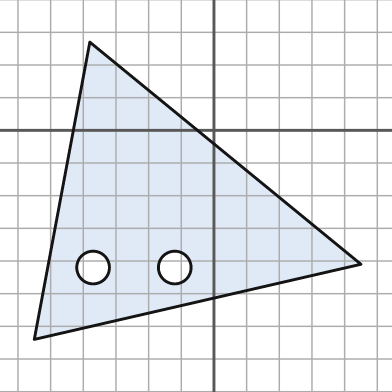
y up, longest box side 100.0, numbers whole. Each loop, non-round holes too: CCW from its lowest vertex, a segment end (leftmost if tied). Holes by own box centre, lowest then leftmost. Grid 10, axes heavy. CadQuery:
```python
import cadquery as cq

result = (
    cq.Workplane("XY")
    .moveTo(-55.0, -64.0)
    .lineTo(45.0, -41.0)
    .lineTo(-38.0, 27.0)
    .close()
    .moveTo(-37.0, -42.0)
    .circle(5.0)
    .moveTo(-12.0, -42.0)
    .circle(5.0)
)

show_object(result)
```